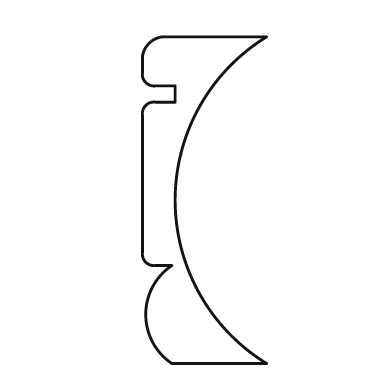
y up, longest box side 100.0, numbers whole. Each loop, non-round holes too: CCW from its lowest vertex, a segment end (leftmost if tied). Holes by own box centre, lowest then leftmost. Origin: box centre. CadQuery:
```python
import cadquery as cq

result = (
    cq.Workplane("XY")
    .moveTo(-10.0, -50.0)
    .lineTo(19.0, -50.0)
    .threePointArc((-9.0, 0.0), (19.0, 50.0))
    .lineTo(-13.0, 50.0)
    .threePointArc((-17.0, 48.0), (-19.0, 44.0))
    .lineTo(-19.0, 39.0)
    .threePointArc((-18.0, 36.0), (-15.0, 35.0))
    .lineTo(-9.0, 35.0)
    .lineTo(-9.0, 30.0)
    .lineTo(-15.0, 30.0)
    .threePointArc((-18.0, 29.0), (-19.0, 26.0))
    .lineTo(-19.0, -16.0)
    .threePointArc((-18.0, -19.0), (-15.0, -20.0))
    .lineTo(-10.0, -20.0)
    .threePointArc((-18.0, -35.0), (-10.0, -50.0))
    .close()
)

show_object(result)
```